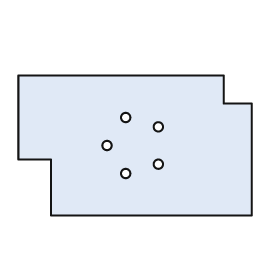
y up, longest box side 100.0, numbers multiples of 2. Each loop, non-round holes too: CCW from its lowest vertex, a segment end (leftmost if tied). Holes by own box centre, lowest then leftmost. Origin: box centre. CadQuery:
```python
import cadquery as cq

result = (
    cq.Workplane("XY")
    .moveTo(-36.0, -30.0)
    .lineTo(50.0, -30.0)
    .lineTo(50.0, 18.0)
    .lineTo(38.0, 18.0)
    .lineTo(38.0, 30.0)
    .lineTo(-50.0, 30.0)
    .lineTo(-50.0, -6.0)
    .lineTo(-36.0, -6.0)
    .close()
    .moveTo(-4.0, -12.0)
    .circle(2.0)
    .moveTo(10.0, -8.0)
    .circle(2.0)
    .moveTo(-12.0, 0.0)
    .circle(2.0)
    .moveTo(10.0, 8.0)
    .circle(2.0)
    .moveTo(-4.0, 12.0)
    .circle(2.0)
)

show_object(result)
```